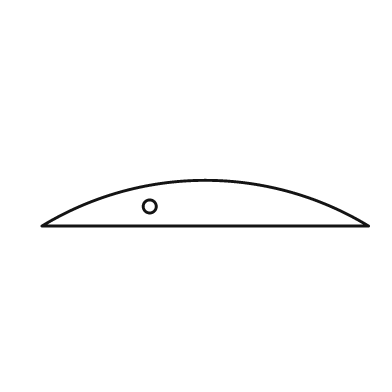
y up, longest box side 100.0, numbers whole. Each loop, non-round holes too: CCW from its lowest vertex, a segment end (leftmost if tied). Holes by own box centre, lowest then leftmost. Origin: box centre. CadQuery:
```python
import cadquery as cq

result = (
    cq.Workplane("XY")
    .moveTo(-50.0, -7.0)
    .lineTo(50.0, -7.0)
    .threePointArc((0.0, 7.0), (-50.0, -7.0))
    .close()
    .moveTo(-17.0, -1.0)
    .circle(2.0)
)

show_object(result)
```